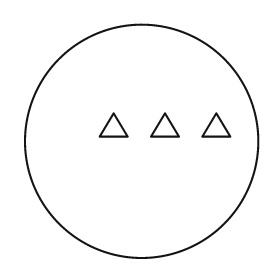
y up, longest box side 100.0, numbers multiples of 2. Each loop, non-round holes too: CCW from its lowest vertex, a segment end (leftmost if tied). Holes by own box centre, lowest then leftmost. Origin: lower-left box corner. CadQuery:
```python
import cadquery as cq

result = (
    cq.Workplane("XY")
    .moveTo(50.0, 50.0)
    .circle(50.0)
    .moveTo(32.0, 52.0)
    .lineTo(44.0, 52.0)
    .lineTo(38.0, 62.0)
    .close()
    .moveTo(54.0, 52.0)
    .lineTo(66.0, 52.0)
    .lineTo(60.0, 62.0)
    .close()
    .moveTo(76.0, 52.0)
    .lineTo(88.0, 52.0)
    .lineTo(82.0, 62.0)
    .close()
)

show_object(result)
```